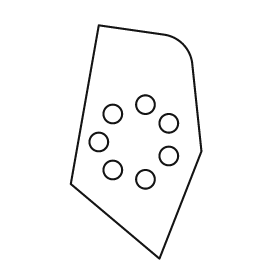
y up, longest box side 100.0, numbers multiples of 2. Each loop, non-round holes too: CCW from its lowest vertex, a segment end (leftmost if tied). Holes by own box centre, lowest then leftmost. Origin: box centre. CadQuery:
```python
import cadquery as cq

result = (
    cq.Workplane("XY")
    .moveTo(10.0, -50.0)
    .lineTo(28.0, -4.0)
    .lineTo(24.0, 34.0)
    .threePointArc((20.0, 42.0), (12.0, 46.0))
    .lineTo(-16.0, 50.0)
    .lineTo(-28.0, -18.0)
    .close()
    .moveTo(4.0, -16.0)
    .circle(4.0)
    .moveTo(-10.0, -12.0)
    .circle(4.0)
    .moveTo(14.0, -6.0)
    .circle(4.0)
    .moveTo(-16.0, 0.0)
    .circle(4.0)
    .moveTo(14.0, 8.0)
    .circle(4.0)
    .moveTo(-10.0, 12.0)
    .circle(4.0)
    .moveTo(4.0, 16.0)
    .circle(4.0)
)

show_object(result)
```